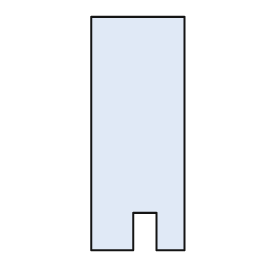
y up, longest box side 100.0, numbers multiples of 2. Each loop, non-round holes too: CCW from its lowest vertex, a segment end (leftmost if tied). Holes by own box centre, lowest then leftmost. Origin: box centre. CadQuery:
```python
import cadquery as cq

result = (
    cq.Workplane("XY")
    .moveTo(-20.0, -50.0)
    .lineTo(-2.0, -50.0)
    .lineTo(-2.0, -34.0)
    .lineTo(8.0, -34.0)
    .lineTo(8.0, -50.0)
    .lineTo(20.0, -50.0)
    .lineTo(20.0, 50.0)
    .lineTo(-20.0, 50.0)
    .close()
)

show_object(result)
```